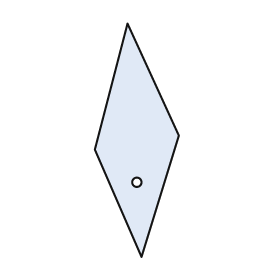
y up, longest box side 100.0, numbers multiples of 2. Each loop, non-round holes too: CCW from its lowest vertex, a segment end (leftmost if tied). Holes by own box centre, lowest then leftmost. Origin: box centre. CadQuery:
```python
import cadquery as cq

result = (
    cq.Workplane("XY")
    .moveTo(2.0, -50.0)
    .lineTo(18.0, 2.0)
    .lineTo(-4.0, 50.0)
    .lineTo(-18.0, -4.0)
    .close()
    .moveTo(0.0, -18.0)
    .circle(2.0)
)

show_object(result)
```